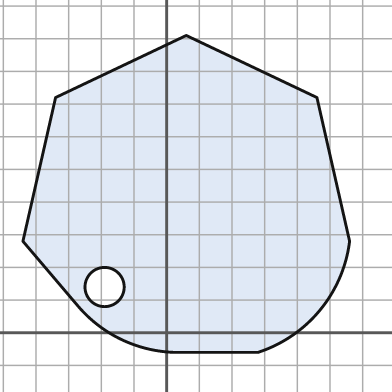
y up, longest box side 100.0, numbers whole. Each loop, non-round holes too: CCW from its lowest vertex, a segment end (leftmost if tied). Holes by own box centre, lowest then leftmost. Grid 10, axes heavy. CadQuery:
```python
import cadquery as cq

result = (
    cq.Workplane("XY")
    .moveTo(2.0, -6.0)
    .lineTo(28.0, -6.0)
    .threePointArc((47.0, 7.0), (56.0, 28.0))
    .lineTo(46.0, 72.0)
    .lineTo(6.0, 91.0)
    .lineTo(-34.0, 72.0)
    .lineTo(-44.0, 28.0)
    .lineTo(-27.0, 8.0)
    .threePointArc((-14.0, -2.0), (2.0, -6.0))
    .close()
    .moveTo(-19.0, 14.0)
    .circle(6.0)
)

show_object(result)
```